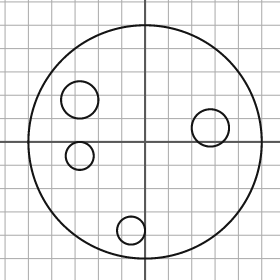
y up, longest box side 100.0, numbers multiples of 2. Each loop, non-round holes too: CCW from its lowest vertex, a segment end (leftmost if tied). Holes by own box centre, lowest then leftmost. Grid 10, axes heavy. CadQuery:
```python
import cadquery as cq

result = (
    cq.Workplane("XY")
    .moveTo(0.0, 0.0)
    .circle(50.0)
    .moveTo(-6.0, -38.0)
    .circle(6.0)
    .moveTo(-28.0, -6.0)
    .circle(6.0)
    .moveTo(28.0, 6.0)
    .circle(8.0)
    .moveTo(-28.0, 18.0)
    .circle(8.0)
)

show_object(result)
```